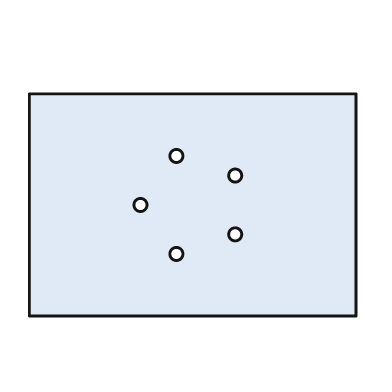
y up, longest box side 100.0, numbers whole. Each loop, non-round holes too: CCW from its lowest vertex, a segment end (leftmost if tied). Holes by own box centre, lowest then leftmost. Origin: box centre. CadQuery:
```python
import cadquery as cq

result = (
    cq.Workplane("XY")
    .moveTo(-50.0, -34.0)
    .lineTo(50.0, -34.0)
    .lineTo(50.0, 34.0)
    .lineTo(-50.0, 34.0)
    .close()
    .moveTo(-5.0, -15.0)
    .circle(2.0)
    .moveTo(13.0, -9.0)
    .circle(2.0)
    .moveTo(-16.0, 0.0)
    .circle(2.0)
    .moveTo(13.0, 9.0)
    .circle(2.0)
    .moveTo(-5.0, 15.0)
    .circle(2.0)
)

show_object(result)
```